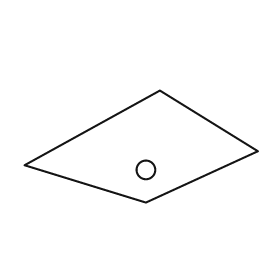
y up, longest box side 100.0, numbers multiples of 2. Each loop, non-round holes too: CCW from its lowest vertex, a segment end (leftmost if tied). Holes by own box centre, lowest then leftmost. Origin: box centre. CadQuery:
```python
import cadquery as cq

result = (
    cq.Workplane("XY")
    .moveTo(2.0, -24.0)
    .lineTo(50.0, -2.0)
    .lineTo(8.0, 24.0)
    .lineTo(-50.0, -8.0)
    .close()
    .moveTo(2.0, -10.0)
    .circle(4.0)
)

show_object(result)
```